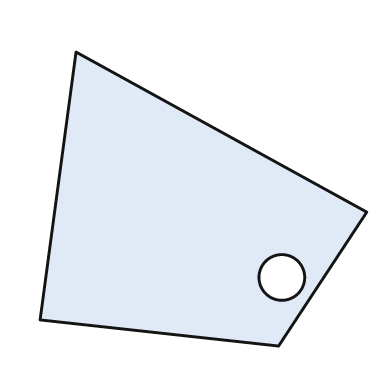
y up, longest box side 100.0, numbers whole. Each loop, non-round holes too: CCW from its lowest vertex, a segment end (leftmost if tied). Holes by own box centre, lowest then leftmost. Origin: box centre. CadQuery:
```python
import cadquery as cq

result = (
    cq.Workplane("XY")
    .moveTo(23.0, -45.0)
    .lineTo(50.0, -4.0)
    .lineTo(-39.0, 45.0)
    .lineTo(-50.0, -37.0)
    .close()
    .moveTo(24.0, -24.0)
    .circle(7.0)
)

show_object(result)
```